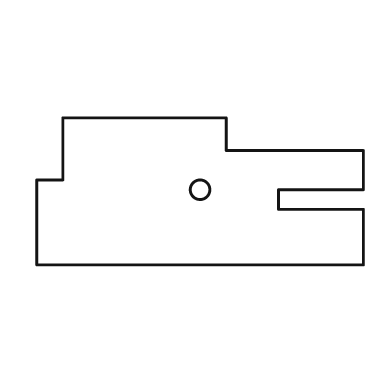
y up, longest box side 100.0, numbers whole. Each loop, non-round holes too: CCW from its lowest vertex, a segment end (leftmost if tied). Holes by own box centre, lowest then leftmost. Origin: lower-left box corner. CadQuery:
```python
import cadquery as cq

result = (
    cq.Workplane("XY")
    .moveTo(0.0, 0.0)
    .lineTo(100.0, 0.0)
    .lineTo(100.0, 17.0)
    .lineTo(74.0, 17.0)
    .lineTo(74.0, 23.0)
    .lineTo(100.0, 23.0)
    .lineTo(100.0, 35.0)
    .lineTo(58.0, 35.0)
    .lineTo(58.0, 45.0)
    .lineTo(8.0, 45.0)
    .lineTo(8.0, 26.0)
    .lineTo(0.0, 26.0)
    .close()
    .moveTo(50.0, 23.0)
    .circle(3.0)
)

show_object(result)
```